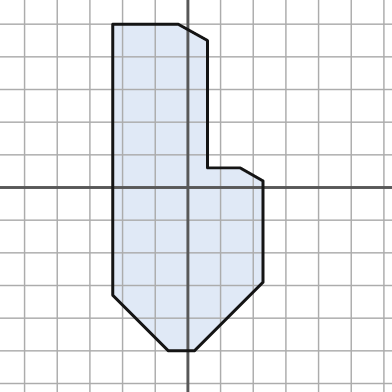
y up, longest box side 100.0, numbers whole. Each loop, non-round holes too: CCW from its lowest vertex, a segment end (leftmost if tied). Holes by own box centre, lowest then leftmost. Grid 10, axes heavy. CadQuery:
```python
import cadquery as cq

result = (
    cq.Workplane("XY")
    .moveTo(-6.0, -50.0)
    .lineTo(2.0, -50.0)
    .lineTo(23.0, -29.0)
    .lineTo(23.0, 2.0)
    .lineTo(16.0, 6.0)
    .lineTo(6.0, 6.0)
    .lineTo(6.0, 45.0)
    .lineTo(-3.0, 50.0)
    .lineTo(-23.0, 50.0)
    .lineTo(-23.0, -33.0)
    .close()
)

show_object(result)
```